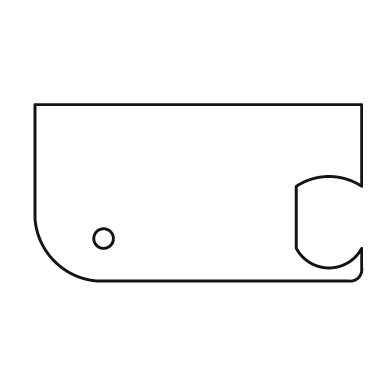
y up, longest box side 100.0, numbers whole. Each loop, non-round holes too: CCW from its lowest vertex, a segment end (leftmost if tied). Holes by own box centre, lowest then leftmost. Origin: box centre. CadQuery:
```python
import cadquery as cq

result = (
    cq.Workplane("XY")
    .moveTo(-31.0, -27.0)
    .lineTo(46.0, -27.0)
    .threePointArc((49.0, -26.0), (50.0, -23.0))
    .lineTo(50.0, -17.0)
    .threePointArc((40.0, -23.0), (30.0, -17.0))
    .lineTo(30.0, 2.0)
    .threePointArc((40.0, 5.0), (50.0, 2.0))
    .lineTo(50.0, 27.0)
    .lineTo(-50.0, 27.0)
    .lineTo(-50.0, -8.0)
    .threePointArc((-44.0, -21.0), (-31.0, -27.0))
    .close()
    .moveTo(-29.0, -14.0)
    .circle(3.0)
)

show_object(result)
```